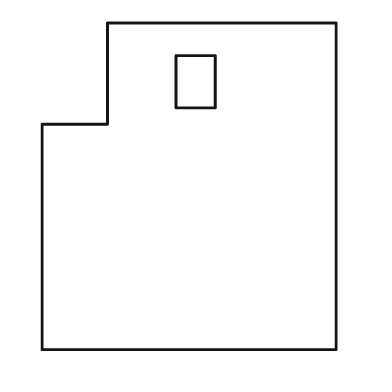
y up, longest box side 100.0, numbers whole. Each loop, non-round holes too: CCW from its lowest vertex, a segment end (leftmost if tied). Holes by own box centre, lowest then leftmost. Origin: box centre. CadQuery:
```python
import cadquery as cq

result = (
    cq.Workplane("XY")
    .moveTo(-45.0, -50.0)
    .lineTo(45.0, -50.0)
    .lineTo(45.0, 50.0)
    .lineTo(-25.0, 50.0)
    .lineTo(-25.0, 19.0)
    .lineTo(-45.0, 19.0)
    .close()
    .moveTo(-4.0, 24.0)
    .lineTo(8.0, 24.0)
    .lineTo(8.0, 40.0)
    .lineTo(-4.0, 40.0)
    .close()
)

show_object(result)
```